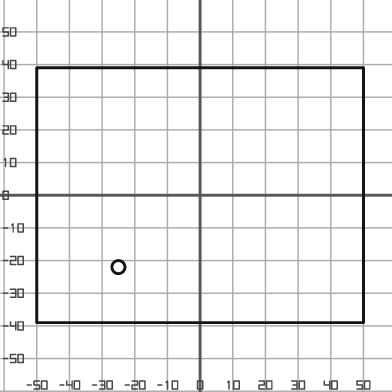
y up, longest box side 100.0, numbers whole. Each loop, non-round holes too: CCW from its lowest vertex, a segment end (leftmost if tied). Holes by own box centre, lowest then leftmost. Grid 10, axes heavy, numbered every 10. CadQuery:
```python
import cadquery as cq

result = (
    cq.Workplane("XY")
    .moveTo(-50.0, -39.0)
    .lineTo(50.0, -39.0)
    .lineTo(50.0, 39.0)
    .lineTo(-50.0, 39.0)
    .close()
    .moveTo(-25.0, -22.0)
    .circle(2.0)
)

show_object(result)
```